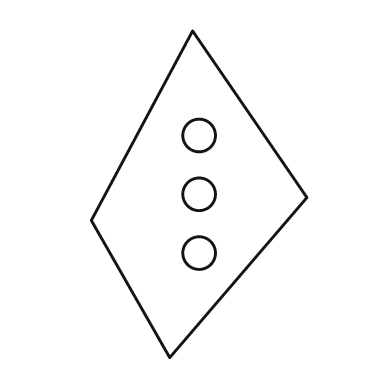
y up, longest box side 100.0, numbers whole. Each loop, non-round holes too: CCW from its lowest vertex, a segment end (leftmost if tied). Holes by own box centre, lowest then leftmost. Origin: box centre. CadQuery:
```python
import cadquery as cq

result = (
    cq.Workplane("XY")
    .moveTo(-9.0, -50.0)
    .lineTo(33.0, -1.0)
    .lineTo(-2.0, 50.0)
    .lineTo(-33.0, -8.0)
    .close()
    .moveTo(0.0, -18.0)
    .circle(5.0)
    .moveTo(0.0, 0.0)
    .circle(5.0)
    .moveTo(0.0, 18.0)
    .circle(5.0)
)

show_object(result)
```